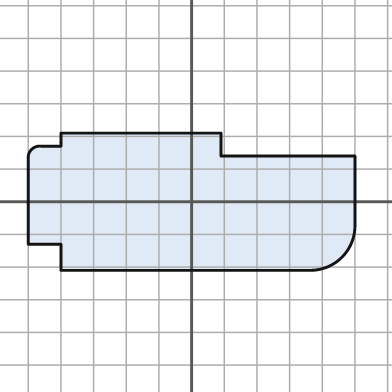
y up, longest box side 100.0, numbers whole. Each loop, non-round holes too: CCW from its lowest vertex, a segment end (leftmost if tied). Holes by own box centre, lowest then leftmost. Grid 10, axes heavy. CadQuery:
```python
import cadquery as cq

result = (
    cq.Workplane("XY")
    .moveTo(-40.0, -21.0)
    .lineTo(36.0, -21.0)
    .threePointArc((46.0, -17.0), (50.0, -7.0))
    .lineTo(50.0, 14.0)
    .lineTo(9.0, 14.0)
    .lineTo(9.0, 21.0)
    .lineTo(-40.0, 21.0)
    .lineTo(-40.0, 17.0)
    .lineTo(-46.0, 17.0)
    .threePointArc((-49.0, 16.0), (-50.0, 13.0))
    .lineTo(-50.0, -13.0)
    .lineTo(-40.0, -13.0)
    .close()
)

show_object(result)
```